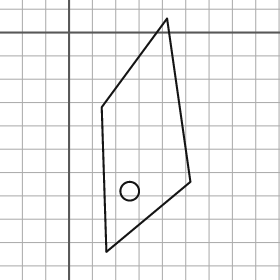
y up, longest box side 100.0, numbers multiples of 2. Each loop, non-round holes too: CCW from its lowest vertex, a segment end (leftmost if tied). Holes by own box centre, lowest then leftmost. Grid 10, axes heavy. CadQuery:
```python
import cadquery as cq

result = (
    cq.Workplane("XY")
    .moveTo(16.0, -94.0)
    .lineTo(52.0, -64.0)
    .lineTo(42.0, 6.0)
    .lineTo(14.0, -32.0)
    .close()
    .moveTo(26.0, -68.0)
    .circle(4.0)
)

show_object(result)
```